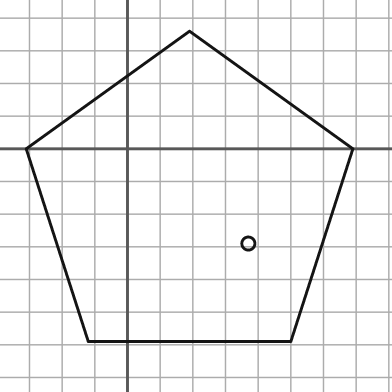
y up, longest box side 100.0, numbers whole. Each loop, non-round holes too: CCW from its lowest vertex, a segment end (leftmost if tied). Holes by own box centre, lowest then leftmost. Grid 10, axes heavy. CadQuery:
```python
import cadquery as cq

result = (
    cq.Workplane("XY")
    .moveTo(-12.0, -59.0)
    .lineTo(50.0, -59.0)
    .lineTo(69.0, 0.0)
    .lineTo(19.0, 36.0)
    .lineTo(-31.0, 0.0)
    .close()
    .moveTo(37.0, -29.0)
    .circle(2.0)
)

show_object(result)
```